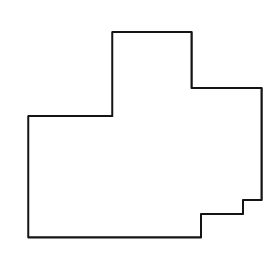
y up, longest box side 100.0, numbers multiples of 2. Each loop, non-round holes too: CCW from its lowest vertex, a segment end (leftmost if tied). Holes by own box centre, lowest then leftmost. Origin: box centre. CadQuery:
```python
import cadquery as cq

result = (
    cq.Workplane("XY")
    .moveTo(-50.0, -44.0)
    .lineTo(24.0, -44.0)
    .lineTo(24.0, -34.0)
    .lineTo(42.0, -34.0)
    .lineTo(42.0, -28.0)
    .lineTo(50.0, -28.0)
    .lineTo(50.0, 20.0)
    .lineTo(20.0, 20.0)
    .lineTo(20.0, 44.0)
    .lineTo(-14.0, 44.0)
    .lineTo(-14.0, 8.0)
    .lineTo(-50.0, 8.0)
    .close()
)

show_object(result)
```